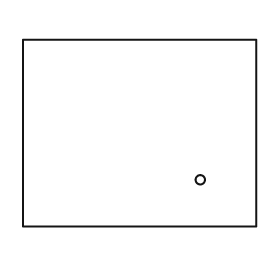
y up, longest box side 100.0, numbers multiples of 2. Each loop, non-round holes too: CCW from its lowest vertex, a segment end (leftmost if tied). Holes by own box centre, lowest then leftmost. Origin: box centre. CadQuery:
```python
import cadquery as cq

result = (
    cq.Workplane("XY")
    .moveTo(-50.0, -40.0)
    .lineTo(50.0, -40.0)
    .lineTo(50.0, 40.0)
    .lineTo(-50.0, 40.0)
    .close()
    .moveTo(26.0, -20.0)
    .circle(2.0)
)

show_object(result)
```